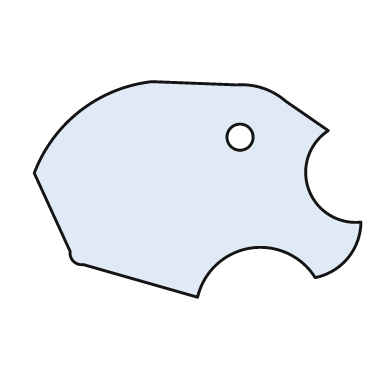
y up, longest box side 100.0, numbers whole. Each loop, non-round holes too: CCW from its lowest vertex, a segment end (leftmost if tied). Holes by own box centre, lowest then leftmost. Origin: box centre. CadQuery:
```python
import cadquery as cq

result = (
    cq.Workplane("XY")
    .moveTo(0.0, -33.0)
    .threePointArc((16.0, -18.0), (36.0, -27.0))
    .threePointArc((46.0, -21.0), (50.0, -10.0))
    .threePointArc((34.0, 0.0), (40.0, 18.0))
    .lineTo(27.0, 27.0)
    .threePointArc((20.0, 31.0), (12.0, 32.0))
    .lineTo(-14.0, 33.0)
    .threePointArc((-36.0, 24.0), (-50.0, 5.0))
    .lineTo(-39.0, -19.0)
    .threePointArc((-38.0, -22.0), (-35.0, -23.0))
    .close()
    .moveTo(13.0, 16.0)
    .circle(4.0)
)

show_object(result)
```